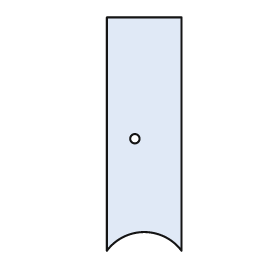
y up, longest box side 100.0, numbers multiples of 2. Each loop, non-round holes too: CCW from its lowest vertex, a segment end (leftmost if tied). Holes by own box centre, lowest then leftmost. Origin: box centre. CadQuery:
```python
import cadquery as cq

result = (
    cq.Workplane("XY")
    .moveTo(-16.0, -50.0)
    .threePointArc((0.0, -42.0), (16.0, -50.0))
    .lineTo(16.0, 50.0)
    .lineTo(-16.0, 50.0)
    .close()
    .moveTo(-4.0, -2.0)
    .circle(2.0)
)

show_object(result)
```